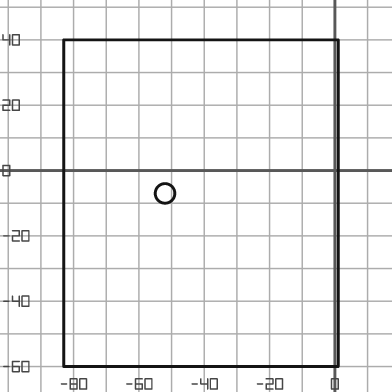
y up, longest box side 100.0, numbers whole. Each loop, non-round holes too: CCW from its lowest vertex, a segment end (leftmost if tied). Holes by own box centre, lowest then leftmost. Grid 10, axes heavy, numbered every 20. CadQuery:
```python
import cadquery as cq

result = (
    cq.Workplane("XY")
    .moveTo(-83.0, -60.0)
    .lineTo(1.0, -60.0)
    .lineTo(1.0, 40.0)
    .lineTo(-83.0, 40.0)
    .close()
    .moveTo(-52.0, -7.0)
    .circle(3.0)
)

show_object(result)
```